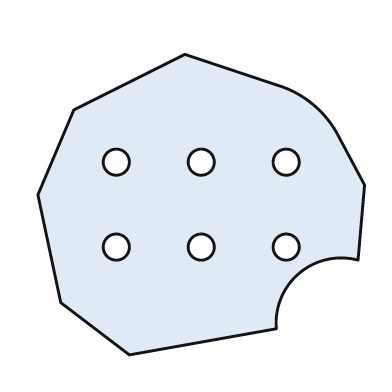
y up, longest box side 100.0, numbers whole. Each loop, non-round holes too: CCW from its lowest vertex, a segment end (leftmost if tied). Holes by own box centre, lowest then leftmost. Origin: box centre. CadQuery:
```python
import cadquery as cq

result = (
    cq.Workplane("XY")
    .moveTo(-22.0, -46.0)
    .lineTo(23.0, -38.0)
    .threePointArc((30.0, -21.0), (48.0, -17.0))
    .lineTo(50.0, 6.0)
    .lineTo(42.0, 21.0)
    .threePointArc((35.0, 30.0), (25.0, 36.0))
    .lineTo(-5.0, 46.0)
    .lineTo(-39.0, 29.0)
    .lineTo(-50.0, 3.0)
    .lineTo(-43.0, -30.0)
    .close()
    .moveTo(-26.0, -13.0)
    .circle(4.0)
    .moveTo(0.0, -13.0)
    .circle(4.0)
    .moveTo(26.0, -13.0)
    .circle(4.0)
    .moveTo(-26.0, 13.0)
    .circle(4.0)
    .moveTo(0.0, 13.0)
    .circle(4.0)
    .moveTo(26.0, 13.0)
    .circle(4.0)
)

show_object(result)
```